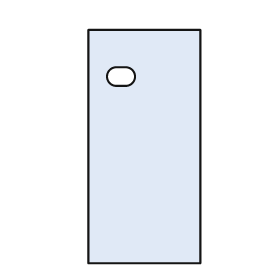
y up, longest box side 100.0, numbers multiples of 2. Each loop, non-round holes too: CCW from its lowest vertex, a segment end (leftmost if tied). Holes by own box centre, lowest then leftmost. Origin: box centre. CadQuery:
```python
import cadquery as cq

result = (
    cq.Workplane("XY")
    .moveTo(-24.0, -50.0)
    .lineTo(24.0, -50.0)
    .lineTo(24.0, 50.0)
    .lineTo(-24.0, 50.0)
    .close()
    .moveTo(-12.0, 26.0)
    .lineTo(-8.0, 26.0)
    .threePointArc((-4.0, 30.0), (-8.0, 34.0))
    .lineTo(-12.0, 34.0)
    .threePointArc((-16.0, 30.0), (-12.0, 26.0))
    .close()
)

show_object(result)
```